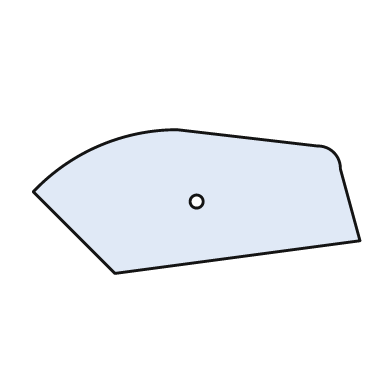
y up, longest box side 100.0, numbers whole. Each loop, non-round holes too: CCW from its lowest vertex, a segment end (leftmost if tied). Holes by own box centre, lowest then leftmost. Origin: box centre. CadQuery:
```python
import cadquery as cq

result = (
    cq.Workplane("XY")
    .moveTo(-25.0, -22.0)
    .lineTo(50.0, -12.0)
    .lineTo(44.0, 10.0)
    .threePointArc((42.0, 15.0), (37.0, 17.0))
    .lineTo(-6.0, 22.0)
    .threePointArc((-30.0, 17.0), (-50.0, 3.0))
    .close()
    .moveTo(0.0, 0.0)
    .circle(2.0)
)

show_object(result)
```